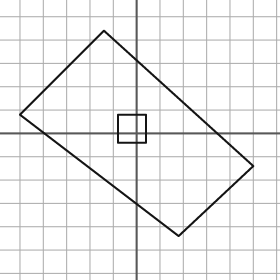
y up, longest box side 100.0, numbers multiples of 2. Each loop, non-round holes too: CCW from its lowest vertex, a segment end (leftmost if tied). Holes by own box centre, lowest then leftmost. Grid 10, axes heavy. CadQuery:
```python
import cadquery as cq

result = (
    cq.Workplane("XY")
    .moveTo(18.0, -44.0)
    .lineTo(50.0, -14.0)
    .lineTo(-14.0, 44.0)
    .lineTo(-50.0, 8.0)
    .close()
    .moveTo(-8.0, -4.0)
    .lineTo(4.0, -4.0)
    .lineTo(4.0, 8.0)
    .lineTo(-8.0, 8.0)
    .close()
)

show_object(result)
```